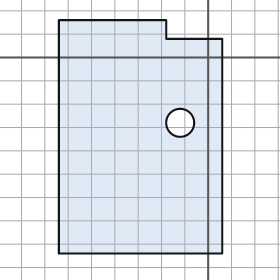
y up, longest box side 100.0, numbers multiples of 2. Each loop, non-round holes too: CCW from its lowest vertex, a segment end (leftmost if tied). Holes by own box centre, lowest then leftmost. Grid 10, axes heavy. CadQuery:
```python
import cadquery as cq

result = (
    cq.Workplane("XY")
    .moveTo(-64.0, -84.0)
    .lineTo(6.0, -84.0)
    .lineTo(6.0, 8.0)
    .lineTo(-18.0, 8.0)
    .lineTo(-18.0, 16.0)
    .lineTo(-64.0, 16.0)
    .close()
    .moveTo(-12.0, -28.0)
    .circle(6.0)
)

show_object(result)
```